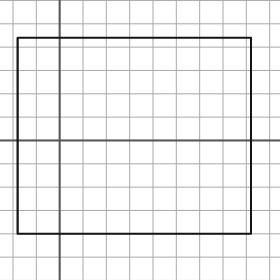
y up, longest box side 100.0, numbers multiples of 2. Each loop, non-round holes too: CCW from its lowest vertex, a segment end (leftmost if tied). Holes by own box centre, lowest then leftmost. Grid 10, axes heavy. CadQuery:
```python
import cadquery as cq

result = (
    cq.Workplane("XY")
    .moveTo(-18.0, -40.0)
    .lineTo(82.0, -40.0)
    .lineTo(82.0, 44.0)
    .lineTo(-18.0, 44.0)
    .close()
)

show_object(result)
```